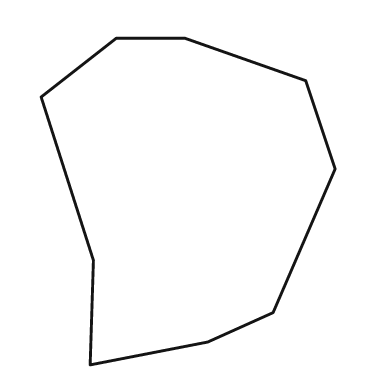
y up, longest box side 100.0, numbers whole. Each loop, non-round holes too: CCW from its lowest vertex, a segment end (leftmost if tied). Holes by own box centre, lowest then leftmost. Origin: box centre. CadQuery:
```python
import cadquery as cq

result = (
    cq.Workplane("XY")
    .moveTo(-30.0, -50.0)
    .lineTo(6.0, -43.0)
    .lineTo(26.0, -34.0)
    .lineTo(45.0, 10.0)
    .lineTo(36.0, 37.0)
    .lineTo(-1.0, 50.0)
    .lineTo(-22.0, 50.0)
    .lineTo(-45.0, 32.0)
    .lineTo(-29.0, -18.0)
    .close()
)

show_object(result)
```